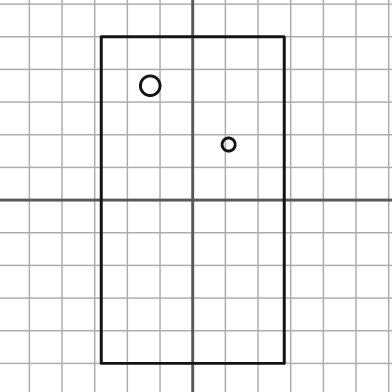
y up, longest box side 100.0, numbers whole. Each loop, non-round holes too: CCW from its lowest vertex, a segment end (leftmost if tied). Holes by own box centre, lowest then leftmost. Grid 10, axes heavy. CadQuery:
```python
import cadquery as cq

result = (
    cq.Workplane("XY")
    .moveTo(-28.0, -50.0)
    .lineTo(28.0, -50.0)
    .lineTo(28.0, 50.0)
    .lineTo(-28.0, 50.0)
    .close()
    .moveTo(11.0, 17.0)
    .circle(2.0)
    .moveTo(-13.0, 35.0)
    .circle(3.0)
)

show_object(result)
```